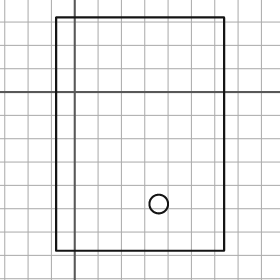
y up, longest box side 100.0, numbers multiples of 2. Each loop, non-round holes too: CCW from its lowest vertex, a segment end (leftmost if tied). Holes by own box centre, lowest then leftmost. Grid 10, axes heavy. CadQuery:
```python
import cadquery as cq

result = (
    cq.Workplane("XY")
    .moveTo(-8.0, -68.0)
    .lineTo(64.0, -68.0)
    .lineTo(64.0, 32.0)
    .lineTo(-8.0, 32.0)
    .close()
    .moveTo(36.0, -48.0)
    .circle(4.0)
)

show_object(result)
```